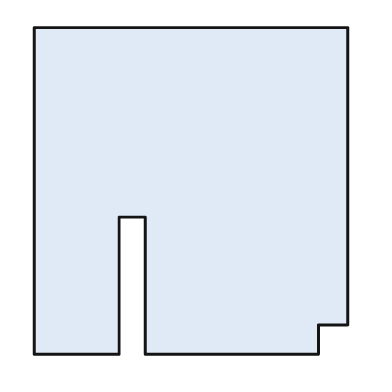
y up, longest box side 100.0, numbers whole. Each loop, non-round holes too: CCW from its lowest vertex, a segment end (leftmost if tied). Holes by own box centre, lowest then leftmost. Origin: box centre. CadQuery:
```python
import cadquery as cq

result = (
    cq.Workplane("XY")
    .moveTo(-48.0, -50.0)
    .lineTo(-22.0, -50.0)
    .lineTo(-22.0, -8.0)
    .lineTo(-14.0, -8.0)
    .lineTo(-14.0, -50.0)
    .lineTo(39.0, -50.0)
    .lineTo(39.0, -41.0)
    .lineTo(48.0, -41.0)
    .lineTo(48.0, 50.0)
    .lineTo(-48.0, 50.0)
    .close()
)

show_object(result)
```